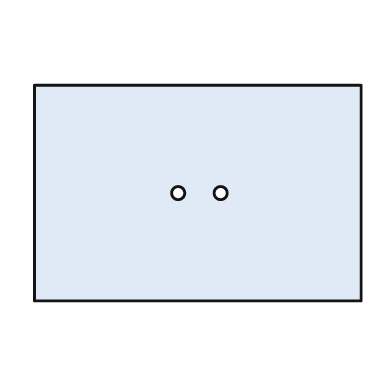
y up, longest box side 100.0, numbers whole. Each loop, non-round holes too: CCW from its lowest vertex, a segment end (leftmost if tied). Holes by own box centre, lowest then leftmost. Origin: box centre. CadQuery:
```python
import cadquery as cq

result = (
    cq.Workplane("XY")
    .moveTo(-50.0, -33.0)
    .lineTo(50.0, -33.0)
    .lineTo(50.0, 33.0)
    .lineTo(-50.0, 33.0)
    .close()
    .moveTo(-6.0, 0.0)
    .circle(2.0)
    .moveTo(7.0, 0.0)
    .circle(2.0)
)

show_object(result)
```